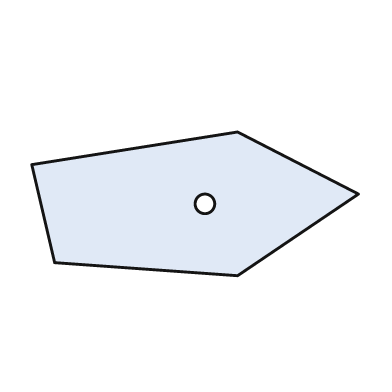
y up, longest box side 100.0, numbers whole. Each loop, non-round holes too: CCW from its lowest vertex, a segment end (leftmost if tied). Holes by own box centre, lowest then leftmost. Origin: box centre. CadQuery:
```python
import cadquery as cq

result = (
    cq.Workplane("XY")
    .moveTo(13.0, -22.0)
    .lineTo(50.0, 3.0)
    .lineTo(13.0, 22.0)
    .lineTo(-50.0, 12.0)
    .lineTo(-43.0, -18.0)
    .close()
    .moveTo(3.0, 0.0)
    .circle(3.0)
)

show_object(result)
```